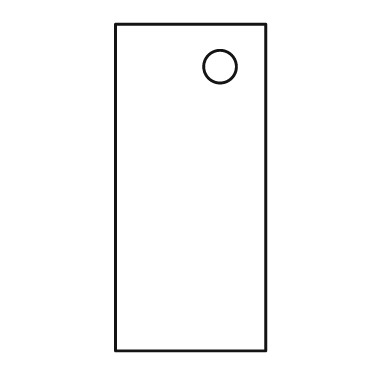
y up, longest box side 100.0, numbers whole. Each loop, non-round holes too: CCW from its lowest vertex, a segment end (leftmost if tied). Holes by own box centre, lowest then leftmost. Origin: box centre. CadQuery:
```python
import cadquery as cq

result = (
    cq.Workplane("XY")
    .moveTo(-23.0, -50.0)
    .lineTo(23.0, -50.0)
    .lineTo(23.0, 50.0)
    .lineTo(-23.0, 50.0)
    .close()
    .moveTo(9.0, 37.0)
    .circle(5.0)
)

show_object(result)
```